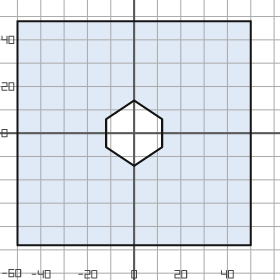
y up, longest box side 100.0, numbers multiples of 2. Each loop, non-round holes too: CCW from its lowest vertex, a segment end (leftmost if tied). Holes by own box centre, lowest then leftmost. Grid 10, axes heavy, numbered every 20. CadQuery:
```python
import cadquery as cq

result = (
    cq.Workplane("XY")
    .moveTo(-50.0, -48.0)
    .lineTo(50.0, -48.0)
    .lineTo(50.0, 48.0)
    .lineTo(-50.0, 48.0)
    .close()
    .moveTo(0.0, -14.0)
    .lineTo(12.0, -6.0)
    .lineTo(12.0, 6.0)
    .lineTo(0.0, 14.0)
    .lineTo(-12.0, 6.0)
    .lineTo(-12.0, -6.0)
    .close()
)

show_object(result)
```